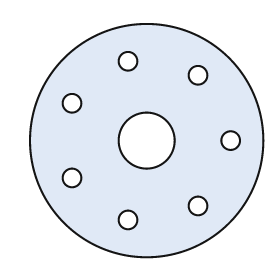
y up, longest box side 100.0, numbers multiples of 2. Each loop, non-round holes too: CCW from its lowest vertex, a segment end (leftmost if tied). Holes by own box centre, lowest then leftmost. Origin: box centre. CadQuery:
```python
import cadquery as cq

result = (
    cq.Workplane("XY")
    .moveTo(0.0, 0.0)
    .circle(50.0)
    .moveTo(-8.0, -34.0)
    .circle(4.0)
    .moveTo(22.0, -28.0)
    .circle(4.0)
    .moveTo(-32.0, -16.0)
    .circle(4.0)
    .moveTo(0.0, 0.0)
    .circle(12.0)
    .moveTo(36.0, 0.0)
    .circle(4.0)
    .moveTo(-32.0, 16.0)
    .circle(4.0)
    .moveTo(22.0, 28.0)
    .circle(4.0)
    .moveTo(-8.0, 34.0)
    .circle(4.0)
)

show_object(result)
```